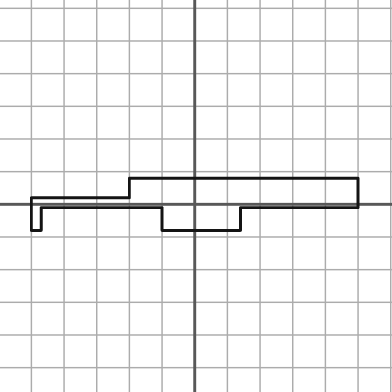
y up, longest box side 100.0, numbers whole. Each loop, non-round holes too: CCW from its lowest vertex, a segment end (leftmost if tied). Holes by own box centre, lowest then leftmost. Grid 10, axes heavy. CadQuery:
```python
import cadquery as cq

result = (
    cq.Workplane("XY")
    .moveTo(-50.0, -8.0)
    .lineTo(-47.0, -8.0)
    .lineTo(-47.0, -1.0)
    .lineTo(-10.0, -1.0)
    .lineTo(-10.0, -8.0)
    .lineTo(14.0, -8.0)
    .lineTo(14.0, -1.0)
    .lineTo(50.0, -1.0)
    .lineTo(50.0, 8.0)
    .lineTo(-20.0, 8.0)
    .lineTo(-20.0, 2.0)
    .lineTo(-50.0, 2.0)
    .close()
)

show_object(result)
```